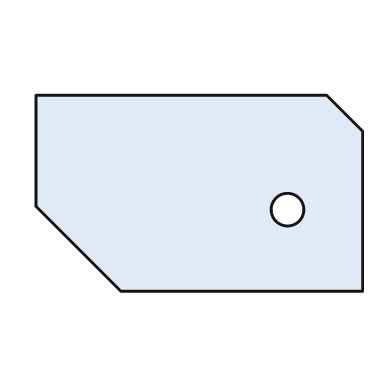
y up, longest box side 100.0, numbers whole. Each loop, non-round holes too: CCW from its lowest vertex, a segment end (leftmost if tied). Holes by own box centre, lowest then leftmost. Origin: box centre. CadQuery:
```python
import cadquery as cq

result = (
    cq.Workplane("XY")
    .moveTo(-24.0, -30.0)
    .lineTo(50.0, -30.0)
    .lineTo(50.0, 19.0)
    .lineTo(39.0, 30.0)
    .lineTo(-50.0, 30.0)
    .lineTo(-50.0, -4.0)
    .close()
    .moveTo(27.0, -5.0)
    .circle(5.0)
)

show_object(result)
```